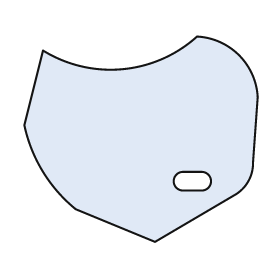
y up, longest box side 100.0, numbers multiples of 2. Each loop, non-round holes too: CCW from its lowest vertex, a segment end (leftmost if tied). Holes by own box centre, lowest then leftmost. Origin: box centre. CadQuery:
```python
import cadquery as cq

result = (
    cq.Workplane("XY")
    .moveTo(6.0, -44.0)
    .lineTo(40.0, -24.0)
    .threePointArc((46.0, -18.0), (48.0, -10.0))
    .lineTo(50.0, 18.0)
    .threePointArc((42.0, 36.0), (24.0, 44.0))
    .threePointArc((-8.0, 30.0), (-42.0, 38.0))
    .lineTo(-50.0, 6.0)
    .threePointArc((-42.0, -14.0), (-28.0, -30.0))
    .close()
    .moveTo(18.0, -22.0)
    .lineTo(26.0, -22.0)
    .threePointArc((30.0, -18.0), (26.0, -14.0))
    .lineTo(18.0, -14.0)
    .threePointArc((14.0, -18.0), (18.0, -22.0))
    .close()
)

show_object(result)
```